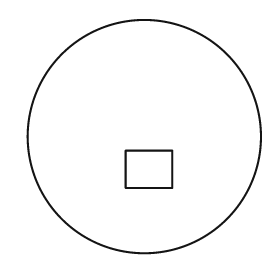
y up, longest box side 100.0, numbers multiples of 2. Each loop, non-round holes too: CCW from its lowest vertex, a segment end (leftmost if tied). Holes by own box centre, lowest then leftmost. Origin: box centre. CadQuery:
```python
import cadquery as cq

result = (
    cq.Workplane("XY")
    .moveTo(0.0, 0.0)
    .circle(50.0)
    .moveTo(-8.0, -22.0)
    .lineTo(12.0, -22.0)
    .lineTo(12.0, -6.0)
    .lineTo(-8.0, -6.0)
    .close()
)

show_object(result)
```